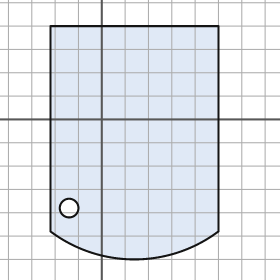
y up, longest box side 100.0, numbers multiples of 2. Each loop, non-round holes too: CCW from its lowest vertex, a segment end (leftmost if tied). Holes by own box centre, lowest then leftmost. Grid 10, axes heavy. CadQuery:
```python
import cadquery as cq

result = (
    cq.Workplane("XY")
    .moveTo(-22.0, -48.0)
    .threePointArc((14.0, -60.0), (50.0, -48.0))
    .lineTo(50.0, 40.0)
    .lineTo(-22.0, 40.0)
    .close()
    .moveTo(-14.0, -38.0)
    .circle(4.0)
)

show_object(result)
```